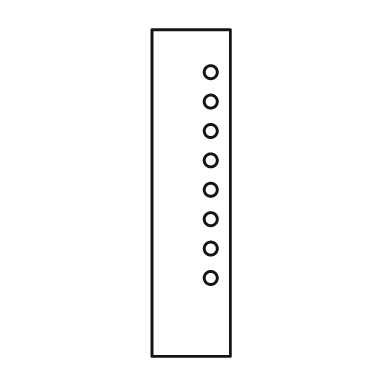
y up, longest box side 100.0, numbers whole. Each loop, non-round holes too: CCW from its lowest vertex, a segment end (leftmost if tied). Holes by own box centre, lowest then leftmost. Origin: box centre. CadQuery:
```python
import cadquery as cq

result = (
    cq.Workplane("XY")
    .moveTo(-12.0, -50.0)
    .lineTo(12.0, -50.0)
    .lineTo(12.0, 50.0)
    .lineTo(-12.0, 50.0)
    .close()
    .moveTo(6.0, -26.0)
    .circle(2.0)
    .moveTo(6.0, -17.0)
    .circle(2.0)
    .moveTo(6.0, -8.0)
    .circle(2.0)
    .moveTo(6.0, 1.0)
    .circle(2.0)
    .moveTo(6.0, 10.0)
    .circle(2.0)
    .moveTo(6.0, 19.0)
    .circle(2.0)
    .moveTo(6.0, 28.0)
    .circle(2.0)
    .moveTo(6.0, 37.0)
    .circle(2.0)
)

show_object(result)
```